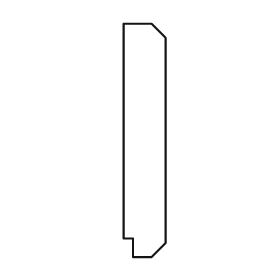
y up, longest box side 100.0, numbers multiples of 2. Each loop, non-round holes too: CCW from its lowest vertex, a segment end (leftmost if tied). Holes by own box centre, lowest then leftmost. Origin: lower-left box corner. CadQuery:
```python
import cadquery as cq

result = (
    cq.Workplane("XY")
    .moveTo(4.0, 0.0)
    .lineTo(12.0, 0.0)
    .lineTo(18.0, 6.0)
    .lineTo(18.0, 94.0)
    .lineTo(12.0, 100.0)
    .lineTo(0.0, 100.0)
    .lineTo(0.0, 8.0)
    .lineTo(4.0, 8.0)
    .close()
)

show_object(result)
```